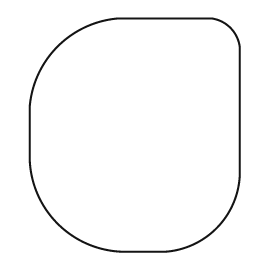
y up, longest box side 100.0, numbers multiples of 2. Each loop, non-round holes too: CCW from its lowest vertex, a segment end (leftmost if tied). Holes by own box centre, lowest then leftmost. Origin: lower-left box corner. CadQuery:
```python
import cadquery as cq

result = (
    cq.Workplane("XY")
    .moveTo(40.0, 0.0)
    .lineTo(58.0, 0.0)
    .threePointArc((80.0, 10.0), (90.0, 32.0))
    .lineTo(90.0, 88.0)
    .threePointArc((86.0, 96.0), (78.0, 100.0))
    .lineTo(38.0, 100.0)
    .threePointArc((12.0, 88.0), (0.0, 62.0))
    .lineTo(0.0, 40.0)
    .threePointArc((12.0, 12.0), (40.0, 0.0))
    .close()
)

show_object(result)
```